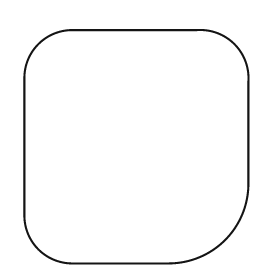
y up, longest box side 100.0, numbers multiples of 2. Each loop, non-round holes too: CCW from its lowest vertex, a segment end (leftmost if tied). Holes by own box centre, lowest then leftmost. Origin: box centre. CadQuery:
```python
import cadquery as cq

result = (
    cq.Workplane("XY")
    .moveTo(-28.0, -50.0)
    .lineTo(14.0, -50.0)
    .threePointArc((38.0, -40.0), (48.0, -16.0))
    .lineTo(48.0, 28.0)
    .threePointArc((42.0, 44.0), (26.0, 50.0))
    .lineTo(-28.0, 50.0)
    .threePointArc((-42.0, 44.0), (-48.0, 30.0))
    .lineTo(-48.0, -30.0)
    .threePointArc((-42.0, -44.0), (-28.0, -50.0))
    .close()
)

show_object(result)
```